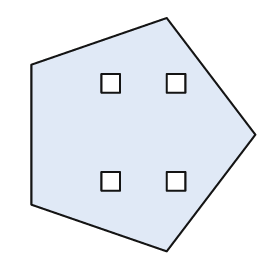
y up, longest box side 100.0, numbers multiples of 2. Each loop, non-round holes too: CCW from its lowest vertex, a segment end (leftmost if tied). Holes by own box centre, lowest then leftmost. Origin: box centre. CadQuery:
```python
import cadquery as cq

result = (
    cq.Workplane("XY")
    .moveTo(10.0, -50.0)
    .lineTo(48.0, 0.0)
    .lineTo(10.0, 50.0)
    .lineTo(-48.0, 30.0)
    .lineTo(-48.0, -30.0)
    .close()
    .moveTo(-18.0, -24.0)
    .lineTo(-10.0, -24.0)
    .lineTo(-10.0, -16.0)
    .lineTo(-18.0, -16.0)
    .close()
    .moveTo(10.0, -24.0)
    .lineTo(18.0, -24.0)
    .lineTo(18.0, -16.0)
    .lineTo(10.0, -16.0)
    .close()
    .moveTo(-18.0, 18.0)
    .lineTo(-10.0, 18.0)
    .lineTo(-10.0, 26.0)
    .lineTo(-18.0, 26.0)
    .close()
    .moveTo(10.0, 18.0)
    .lineTo(18.0, 18.0)
    .lineTo(18.0, 26.0)
    .lineTo(10.0, 26.0)
    .close()
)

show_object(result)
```